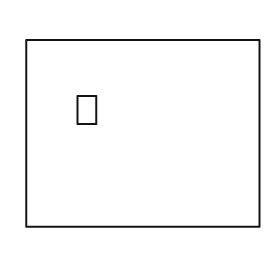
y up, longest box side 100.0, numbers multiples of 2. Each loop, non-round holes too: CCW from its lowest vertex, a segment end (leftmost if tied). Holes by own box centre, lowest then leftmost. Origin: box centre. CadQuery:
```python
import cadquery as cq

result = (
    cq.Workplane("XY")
    .moveTo(-50.0, -40.0)
    .lineTo(50.0, -40.0)
    .lineTo(50.0, 40.0)
    .lineTo(-50.0, 40.0)
    .close()
    .moveTo(-28.0, 4.0)
    .lineTo(-20.0, 4.0)
    .lineTo(-20.0, 16.0)
    .lineTo(-28.0, 16.0)
    .close()
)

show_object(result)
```